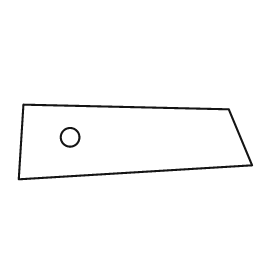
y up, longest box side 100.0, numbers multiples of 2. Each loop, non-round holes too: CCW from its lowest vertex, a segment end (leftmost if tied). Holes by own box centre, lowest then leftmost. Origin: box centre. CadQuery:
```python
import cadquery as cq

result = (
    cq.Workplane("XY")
    .moveTo(-50.0, -16.0)
    .lineTo(50.0, -10.0)
    .lineTo(40.0, 14.0)
    .lineTo(-48.0, 16.0)
    .close()
    .moveTo(-28.0, 2.0)
    .circle(4.0)
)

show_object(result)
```